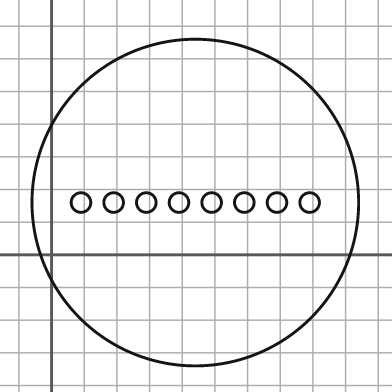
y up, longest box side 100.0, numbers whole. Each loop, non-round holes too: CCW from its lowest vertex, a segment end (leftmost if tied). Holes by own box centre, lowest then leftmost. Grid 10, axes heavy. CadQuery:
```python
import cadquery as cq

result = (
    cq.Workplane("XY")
    .moveTo(44.0, 16.0)
    .circle(50.0)
    .moveTo(9.0, 16.0)
    .circle(3.0)
    .moveTo(19.0, 16.0)
    .circle(3.0)
    .moveTo(29.0, 16.0)
    .circle(3.0)
    .moveTo(39.0, 16.0)
    .circle(3.0)
    .moveTo(49.0, 16.0)
    .circle(3.0)
    .moveTo(59.0, 16.0)
    .circle(3.0)
    .moveTo(69.0, 16.0)
    .circle(3.0)
    .moveTo(79.0, 16.0)
    .circle(3.0)
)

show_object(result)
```